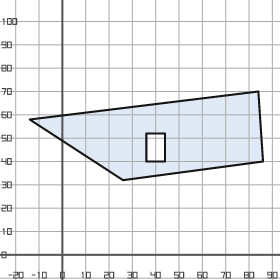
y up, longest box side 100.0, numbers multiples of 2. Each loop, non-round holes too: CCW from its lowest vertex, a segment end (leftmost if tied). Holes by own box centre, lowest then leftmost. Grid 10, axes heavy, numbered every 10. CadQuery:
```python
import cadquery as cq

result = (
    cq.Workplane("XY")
    .moveTo(26.0, 32.0)
    .lineTo(86.0, 40.0)
    .lineTo(84.0, 70.0)
    .lineTo(-14.0, 58.0)
    .close()
    .moveTo(36.0, 40.0)
    .lineTo(44.0, 40.0)
    .lineTo(44.0, 52.0)
    .lineTo(36.0, 52.0)
    .close()
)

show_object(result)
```